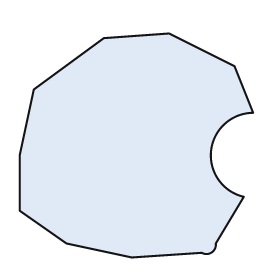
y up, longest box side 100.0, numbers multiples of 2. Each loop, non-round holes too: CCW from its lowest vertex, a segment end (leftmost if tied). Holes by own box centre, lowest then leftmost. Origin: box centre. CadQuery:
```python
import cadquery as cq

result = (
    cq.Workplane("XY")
    .moveTo(-2.0, -48.0)
    .lineTo(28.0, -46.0)
    .threePointArc((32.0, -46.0), (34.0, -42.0))
    .lineTo(46.0, -22.0)
    .threePointArc((32.0, -2.0), (50.0, 14.0))
    .lineTo(42.0, 34.0)
    .lineTo(14.0, 48.0)
    .lineTo(-14.0, 46.0)
    .lineTo(-44.0, 24.0)
    .lineTo(-50.0, -4.0)
    .lineTo(-50.0, -28.0)
    .lineTo(-30.0, -42.0)
    .close()
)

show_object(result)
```